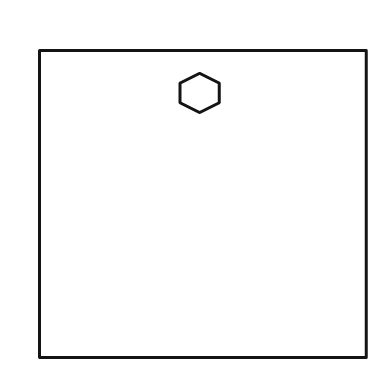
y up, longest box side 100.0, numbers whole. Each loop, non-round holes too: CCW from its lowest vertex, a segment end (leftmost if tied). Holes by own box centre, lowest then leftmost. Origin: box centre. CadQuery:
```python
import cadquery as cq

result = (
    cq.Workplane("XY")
    .moveTo(-50.0, -47.0)
    .lineTo(50.0, -47.0)
    .lineTo(50.0, 47.0)
    .lineTo(-50.0, 47.0)
    .close()
    .moveTo(-1.0, 28.0)
    .lineTo(5.0, 31.0)
    .lineTo(5.0, 37.0)
    .lineTo(-1.0, 40.0)
    .lineTo(-7.0, 37.0)
    .lineTo(-7.0, 31.0)
    .close()
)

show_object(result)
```